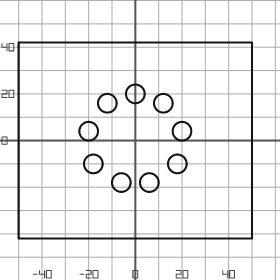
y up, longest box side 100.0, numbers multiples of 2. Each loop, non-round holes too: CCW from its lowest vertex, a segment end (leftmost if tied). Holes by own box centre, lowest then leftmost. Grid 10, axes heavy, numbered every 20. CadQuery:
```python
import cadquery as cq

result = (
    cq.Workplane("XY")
    .moveTo(-50.0, -42.0)
    .lineTo(50.0, -42.0)
    .lineTo(50.0, 42.0)
    .lineTo(-50.0, 42.0)
    .close()
    .moveTo(-6.0, -18.0)
    .circle(4.0)
    .moveTo(6.0, -18.0)
    .circle(4.0)
    .moveTo(-18.0, -10.0)
    .circle(4.0)
    .moveTo(18.0, -10.0)
    .circle(4.0)
    .moveTo(-20.0, 4.0)
    .circle(4.0)
    .moveTo(20.0, 4.0)
    .circle(4.0)
    .moveTo(-12.0, 16.0)
    .circle(4.0)
    .moveTo(12.0, 16.0)
    .circle(4.0)
    .moveTo(0.0, 20.0)
    .circle(4.0)
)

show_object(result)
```